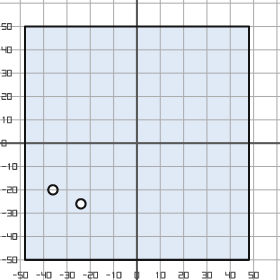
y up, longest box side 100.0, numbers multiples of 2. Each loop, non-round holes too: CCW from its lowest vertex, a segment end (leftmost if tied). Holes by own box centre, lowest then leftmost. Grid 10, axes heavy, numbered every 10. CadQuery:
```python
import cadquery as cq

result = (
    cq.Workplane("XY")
    .moveTo(-48.0, -50.0)
    .lineTo(48.0, -50.0)
    .lineTo(48.0, 50.0)
    .lineTo(-48.0, 50.0)
    .close()
    .moveTo(-24.0, -26.0)
    .circle(2.0)
    .moveTo(-36.0, -20.0)
    .circle(2.0)
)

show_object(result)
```